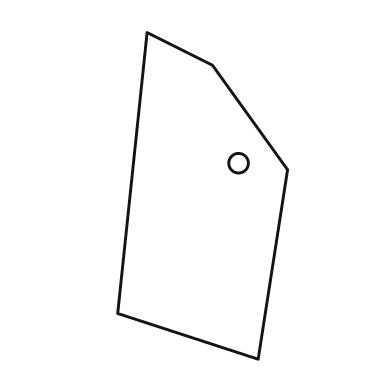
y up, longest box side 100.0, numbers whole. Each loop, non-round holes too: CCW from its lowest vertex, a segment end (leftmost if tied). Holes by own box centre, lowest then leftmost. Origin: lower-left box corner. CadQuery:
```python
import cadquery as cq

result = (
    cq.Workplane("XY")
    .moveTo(43.0, 0.0)
    .lineTo(52.0, 58.0)
    .lineTo(29.0, 90.0)
    .lineTo(9.0, 100.0)
    .lineTo(0.0, 14.0)
    .close()
    .moveTo(37.0, 60.0)
    .circle(3.0)
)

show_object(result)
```